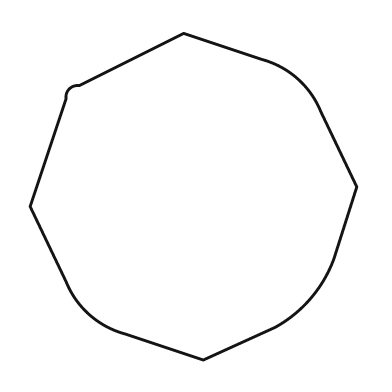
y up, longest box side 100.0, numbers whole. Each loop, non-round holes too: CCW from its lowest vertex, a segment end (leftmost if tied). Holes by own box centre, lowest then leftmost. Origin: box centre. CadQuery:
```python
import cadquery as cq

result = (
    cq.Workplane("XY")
    .moveTo(3.0, -50.0)
    .lineTo(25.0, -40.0)
    .threePointArc((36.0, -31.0), (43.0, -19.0))
    .lineTo(50.0, 3.0)
    .lineTo(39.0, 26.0)
    .threePointArc((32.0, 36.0), (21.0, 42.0))
    .lineTo(-3.0, 50.0)
    .lineTo(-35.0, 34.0)
    .threePointArc((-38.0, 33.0), (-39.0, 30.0))
    .lineTo(-50.0, -3.0)
    .lineTo(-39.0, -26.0)
    .threePointArc((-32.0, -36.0), (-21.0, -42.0))
    .close()
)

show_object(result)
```